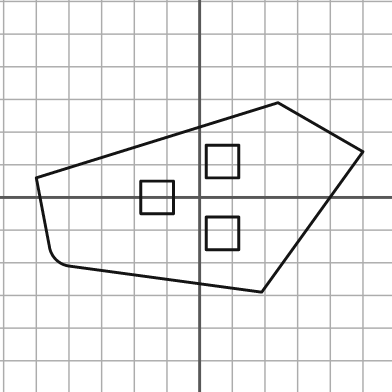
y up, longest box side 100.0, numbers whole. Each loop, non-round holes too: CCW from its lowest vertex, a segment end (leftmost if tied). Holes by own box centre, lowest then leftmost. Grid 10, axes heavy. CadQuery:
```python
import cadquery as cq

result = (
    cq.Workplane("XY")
    .moveTo(19.0, -29.0)
    .lineTo(50.0, 14.0)
    .lineTo(24.0, 29.0)
    .lineTo(-50.0, 6.0)
    .lineTo(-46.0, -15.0)
    .threePointArc((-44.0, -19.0), (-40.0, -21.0))
    .close()
    .moveTo(2.0, -16.0)
    .lineTo(12.0, -16.0)
    .lineTo(12.0, -6.0)
    .lineTo(2.0, -6.0)
    .close()
    .moveTo(-18.0, -5.0)
    .lineTo(-8.0, -5.0)
    .lineTo(-8.0, 5.0)
    .lineTo(-18.0, 5.0)
    .close()
    .moveTo(2.0, 6.0)
    .lineTo(12.0, 6.0)
    .lineTo(12.0, 16.0)
    .lineTo(2.0, 16.0)
    .close()
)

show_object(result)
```